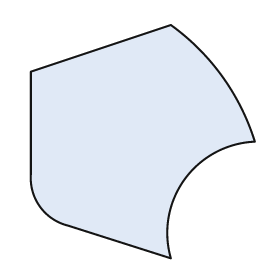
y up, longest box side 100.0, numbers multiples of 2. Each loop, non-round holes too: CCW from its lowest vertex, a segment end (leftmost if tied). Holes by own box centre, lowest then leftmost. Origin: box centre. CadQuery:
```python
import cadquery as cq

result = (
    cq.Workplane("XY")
    .moveTo(12.0, -50.0)
    .threePointArc((18.0, -16.0), (48.0, 0.0))
    .threePointArc((34.0, 28.0), (12.0, 50.0))
    .lineTo(-48.0, 30.0)
    .lineTo(-48.0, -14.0)
    .threePointArc((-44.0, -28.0), (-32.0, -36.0))
    .close()
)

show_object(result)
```